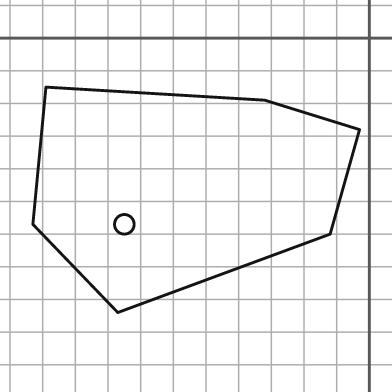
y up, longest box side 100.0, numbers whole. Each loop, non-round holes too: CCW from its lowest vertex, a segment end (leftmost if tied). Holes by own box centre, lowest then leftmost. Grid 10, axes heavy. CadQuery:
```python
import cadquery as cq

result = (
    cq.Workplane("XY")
    .moveTo(-77.0, -84.0)
    .lineTo(-12.0, -60.0)
    .lineTo(-3.0, -28.0)
    .lineTo(-32.0, -19.0)
    .lineTo(-99.0, -15.0)
    .lineTo(-103.0, -57.0)
    .close()
    .moveTo(-75.0, -57.0)
    .circle(3.0)
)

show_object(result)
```